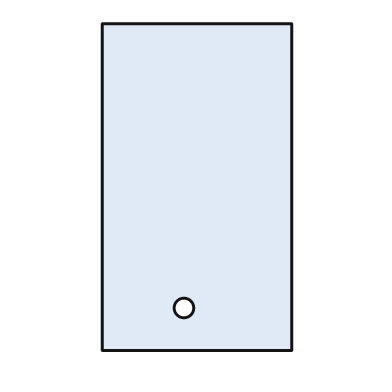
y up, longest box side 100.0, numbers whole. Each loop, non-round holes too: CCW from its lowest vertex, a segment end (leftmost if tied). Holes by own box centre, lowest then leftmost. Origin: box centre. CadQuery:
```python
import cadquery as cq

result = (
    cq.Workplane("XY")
    .moveTo(-29.0, -50.0)
    .lineTo(29.0, -50.0)
    .lineTo(29.0, 50.0)
    .lineTo(-29.0, 50.0)
    .close()
    .moveTo(-4.0, -37.0)
    .circle(3.0)
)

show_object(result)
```